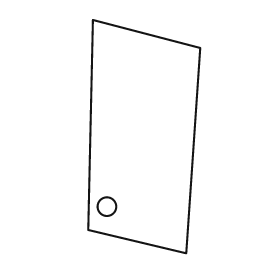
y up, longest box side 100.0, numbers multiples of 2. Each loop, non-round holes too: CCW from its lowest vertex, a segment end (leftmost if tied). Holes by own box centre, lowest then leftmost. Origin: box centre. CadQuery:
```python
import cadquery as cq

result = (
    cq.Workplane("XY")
    .moveTo(18.0, -50.0)
    .lineTo(24.0, 38.0)
    .lineTo(-22.0, 50.0)
    .lineTo(-24.0, -40.0)
    .close()
    .moveTo(-16.0, -30.0)
    .circle(4.0)
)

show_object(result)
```